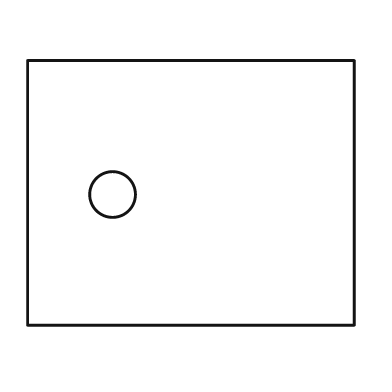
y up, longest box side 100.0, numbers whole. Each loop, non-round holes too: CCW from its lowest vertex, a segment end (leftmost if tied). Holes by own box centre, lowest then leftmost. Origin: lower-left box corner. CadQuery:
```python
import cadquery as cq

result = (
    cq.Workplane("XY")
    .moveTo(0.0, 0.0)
    .lineTo(100.0, 0.0)
    .lineTo(100.0, 81.0)
    .lineTo(0.0, 81.0)
    .close()
    .moveTo(26.0, 40.0)
    .circle(7.0)
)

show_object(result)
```